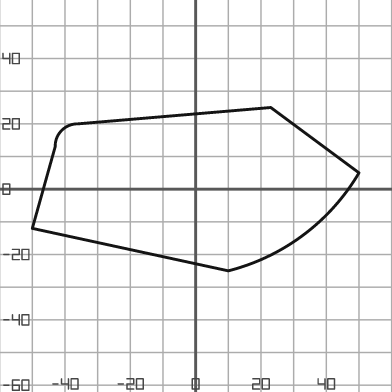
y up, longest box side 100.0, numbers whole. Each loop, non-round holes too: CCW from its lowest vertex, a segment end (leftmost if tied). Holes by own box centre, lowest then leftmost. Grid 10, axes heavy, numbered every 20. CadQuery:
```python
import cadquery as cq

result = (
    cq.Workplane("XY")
    .moveTo(10.0, -25.0)
    .threePointArc((33.0, -14.0), (50.0, 5.0))
    .lineTo(23.0, 25.0)
    .lineTo(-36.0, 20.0)
    .threePointArc((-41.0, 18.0), (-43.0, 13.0))
    .lineTo(-50.0, -12.0)
    .close()
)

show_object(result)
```